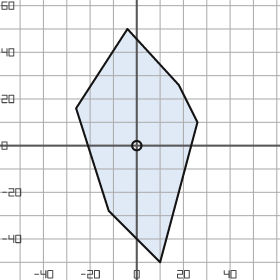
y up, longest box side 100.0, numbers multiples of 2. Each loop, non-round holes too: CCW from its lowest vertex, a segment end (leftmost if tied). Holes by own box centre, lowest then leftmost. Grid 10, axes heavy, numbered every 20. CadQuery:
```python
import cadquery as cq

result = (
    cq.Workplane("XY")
    .moveTo(10.0, -50.0)
    .lineTo(26.0, 10.0)
    .lineTo(18.0, 26.0)
    .lineTo(-4.0, 50.0)
    .lineTo(-26.0, 16.0)
    .lineTo(-12.0, -28.0)
    .close()
    .moveTo(0.0, 0.0)
    .circle(2.0)
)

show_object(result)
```